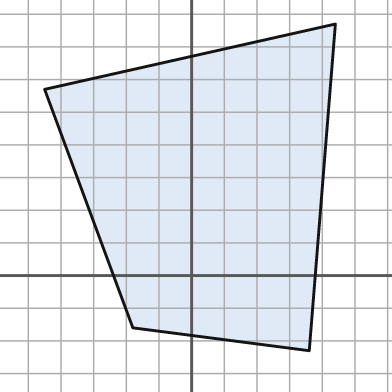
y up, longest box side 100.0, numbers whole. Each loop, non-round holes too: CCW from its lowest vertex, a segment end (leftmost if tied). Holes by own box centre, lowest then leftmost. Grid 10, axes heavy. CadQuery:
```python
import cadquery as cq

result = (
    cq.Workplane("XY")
    .moveTo(36.0, -23.0)
    .lineTo(44.0, 77.0)
    .lineTo(-45.0, 57.0)
    .lineTo(-18.0, -16.0)
    .close()
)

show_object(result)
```